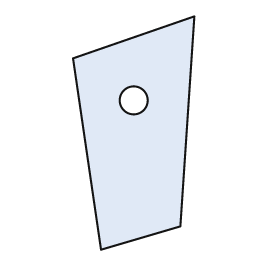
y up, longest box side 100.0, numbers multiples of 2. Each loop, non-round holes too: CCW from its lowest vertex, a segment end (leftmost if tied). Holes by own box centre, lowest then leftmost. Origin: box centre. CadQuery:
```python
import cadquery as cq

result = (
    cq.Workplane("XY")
    .moveTo(-14.0, -50.0)
    .lineTo(20.0, -40.0)
    .lineTo(26.0, 50.0)
    .lineTo(-26.0, 32.0)
    .close()
    .moveTo(0.0, 14.0)
    .circle(6.0)
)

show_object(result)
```